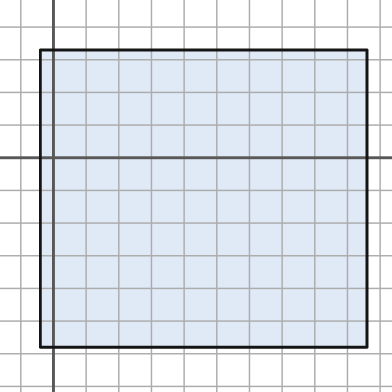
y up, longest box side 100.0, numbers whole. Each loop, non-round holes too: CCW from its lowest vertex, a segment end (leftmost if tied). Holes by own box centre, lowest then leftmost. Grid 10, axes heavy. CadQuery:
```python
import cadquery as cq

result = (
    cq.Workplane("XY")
    .moveTo(-4.0, -58.0)
    .lineTo(96.0, -58.0)
    .lineTo(96.0, 33.0)
    .lineTo(-4.0, 33.0)
    .close()
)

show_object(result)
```